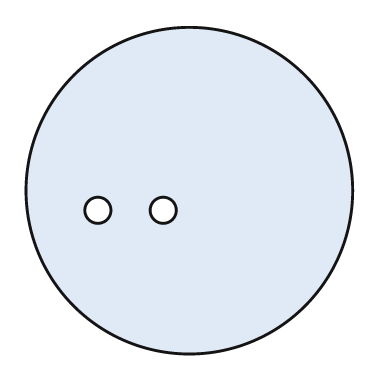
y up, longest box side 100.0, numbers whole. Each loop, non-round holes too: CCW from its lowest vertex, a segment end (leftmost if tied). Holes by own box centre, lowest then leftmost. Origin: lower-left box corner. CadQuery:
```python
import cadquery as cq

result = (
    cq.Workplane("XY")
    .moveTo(50.0, 50.0)
    .circle(50.0)
    .moveTo(22.0, 44.0)
    .circle(4.0)
    .moveTo(42.0, 44.0)
    .circle(4.0)
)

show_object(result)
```